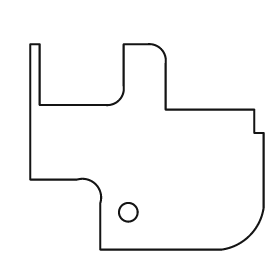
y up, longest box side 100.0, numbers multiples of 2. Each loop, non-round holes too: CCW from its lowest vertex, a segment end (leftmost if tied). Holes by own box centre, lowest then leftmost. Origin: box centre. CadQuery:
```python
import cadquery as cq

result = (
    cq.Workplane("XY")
    .moveTo(-20.0, -44.0)
    .lineTo(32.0, -44.0)
    .threePointArc((44.0, -38.0), (50.0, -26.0))
    .lineTo(50.0, 6.0)
    .lineTo(46.0, 6.0)
    .lineTo(46.0, 16.0)
    .lineTo(8.0, 16.0)
    .lineTo(8.0, 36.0)
    .threePointArc((6.0, 42.0), (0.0, 44.0))
    .lineTo(-10.0, 44.0)
    .lineTo(-10.0, 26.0)
    .threePointArc((-12.0, 20.0), (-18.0, 18.0))
    .lineTo(-46.0, 18.0)
    .lineTo(-46.0, 44.0)
    .lineTo(-50.0, 44.0)
    .lineTo(-50.0, -14.0)
    .lineTo(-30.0, -14.0)
    .threePointArc((-22.0, -16.0), (-20.0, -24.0))
    .close()
    .moveTo(-8.0, -28.0)
    .circle(4.0)
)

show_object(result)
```